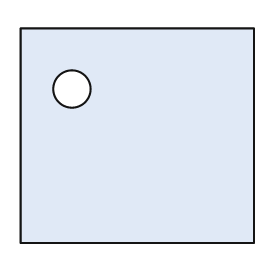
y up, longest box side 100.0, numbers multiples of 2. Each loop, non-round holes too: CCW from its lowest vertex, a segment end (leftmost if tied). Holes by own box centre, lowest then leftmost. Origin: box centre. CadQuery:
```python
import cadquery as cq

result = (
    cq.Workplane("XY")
    .moveTo(-50.0, -46.0)
    .lineTo(50.0, -46.0)
    .lineTo(50.0, 46.0)
    .lineTo(-50.0, 46.0)
    .close()
    .moveTo(-28.0, 20.0)
    .circle(8.0)
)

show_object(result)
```